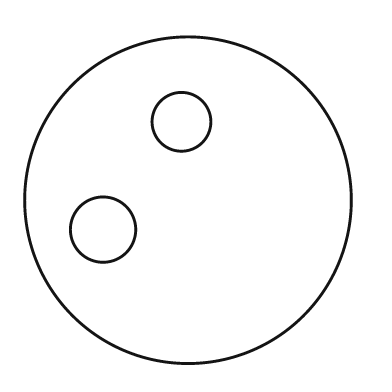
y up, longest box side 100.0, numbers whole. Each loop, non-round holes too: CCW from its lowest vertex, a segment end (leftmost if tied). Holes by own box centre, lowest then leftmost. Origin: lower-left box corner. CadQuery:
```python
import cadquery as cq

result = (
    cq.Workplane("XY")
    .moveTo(50.0, 50.0)
    .circle(50.0)
    .moveTo(24.0, 41.0)
    .circle(10.0)
    .moveTo(48.0, 74.0)
    .circle(9.0)
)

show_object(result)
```